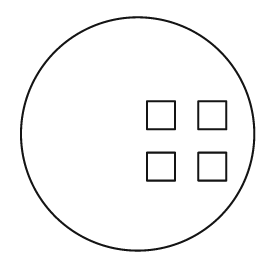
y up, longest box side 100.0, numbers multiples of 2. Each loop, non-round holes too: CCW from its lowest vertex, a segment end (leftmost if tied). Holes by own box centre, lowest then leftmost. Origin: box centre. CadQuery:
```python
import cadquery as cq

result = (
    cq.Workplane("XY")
    .moveTo(0.0, 0.0)
    .circle(50.0)
    .moveTo(4.0, -20.0)
    .lineTo(16.0, -20.0)
    .lineTo(16.0, -8.0)
    .lineTo(4.0, -8.0)
    .close()
    .moveTo(26.0, -20.0)
    .lineTo(38.0, -20.0)
    .lineTo(38.0, -8.0)
    .lineTo(26.0, -8.0)
    .close()
    .moveTo(4.0, 2.0)
    .lineTo(16.0, 2.0)
    .lineTo(16.0, 14.0)
    .lineTo(4.0, 14.0)
    .close()
    .moveTo(26.0, 2.0)
    .lineTo(38.0, 2.0)
    .lineTo(38.0, 14.0)
    .lineTo(26.0, 14.0)
    .close()
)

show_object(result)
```